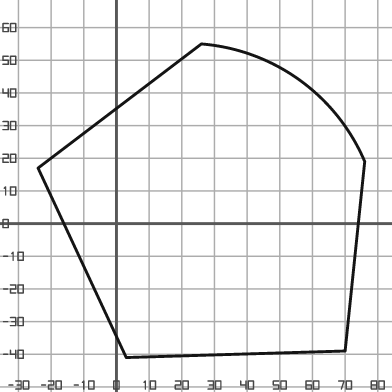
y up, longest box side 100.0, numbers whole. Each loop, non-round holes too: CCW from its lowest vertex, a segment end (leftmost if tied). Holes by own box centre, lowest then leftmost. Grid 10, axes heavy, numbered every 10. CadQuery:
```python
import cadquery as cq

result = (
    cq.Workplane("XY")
    .moveTo(3.0, -41.0)
    .lineTo(70.0, -39.0)
    .lineTo(76.0, 19.0)
    .threePointArc((56.0, 44.0), (26.0, 55.0))
    .lineTo(-24.0, 17.0)
    .close()
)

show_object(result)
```